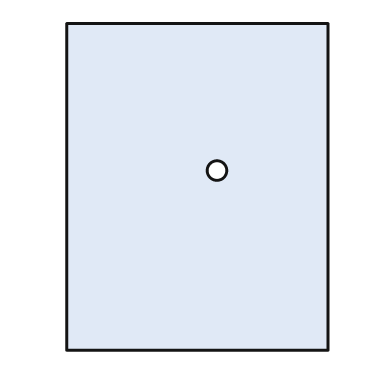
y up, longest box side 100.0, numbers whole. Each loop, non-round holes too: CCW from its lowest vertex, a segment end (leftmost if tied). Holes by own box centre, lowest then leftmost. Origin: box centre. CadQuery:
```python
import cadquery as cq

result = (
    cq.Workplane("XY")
    .moveTo(-40.0, -50.0)
    .lineTo(40.0, -50.0)
    .lineTo(40.0, 50.0)
    .lineTo(-40.0, 50.0)
    .close()
    .moveTo(6.0, 5.0)
    .circle(3.0)
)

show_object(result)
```